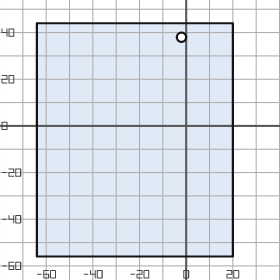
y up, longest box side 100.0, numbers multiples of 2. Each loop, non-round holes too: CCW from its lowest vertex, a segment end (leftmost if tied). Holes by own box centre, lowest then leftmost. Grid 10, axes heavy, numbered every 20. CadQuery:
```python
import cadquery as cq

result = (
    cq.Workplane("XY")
    .moveTo(-64.0, -56.0)
    .lineTo(20.0, -56.0)
    .lineTo(20.0, 44.0)
    .lineTo(-64.0, 44.0)
    .close()
    .moveTo(-2.0, 38.0)
    .circle(2.0)
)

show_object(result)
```